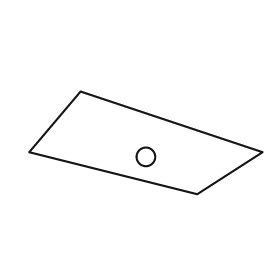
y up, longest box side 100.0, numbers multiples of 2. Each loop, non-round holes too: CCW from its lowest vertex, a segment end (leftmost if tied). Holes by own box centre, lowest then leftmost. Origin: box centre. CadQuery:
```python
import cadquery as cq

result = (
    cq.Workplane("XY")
    .moveTo(22.0, -22.0)
    .lineTo(50.0, -4.0)
    .lineTo(-28.0, 22.0)
    .lineTo(-50.0, -4.0)
    .close()
    .moveTo(0.0, -6.0)
    .circle(4.0)
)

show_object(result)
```